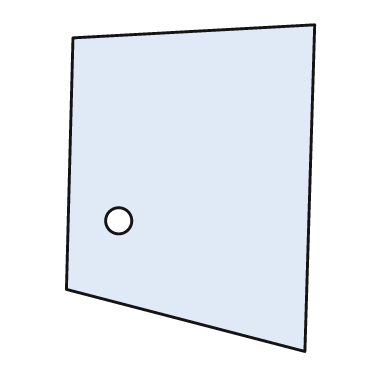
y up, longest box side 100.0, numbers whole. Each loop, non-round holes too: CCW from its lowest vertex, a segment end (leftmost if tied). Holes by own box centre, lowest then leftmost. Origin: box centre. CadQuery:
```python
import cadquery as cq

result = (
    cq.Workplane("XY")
    .moveTo(35.0, -50.0)
    .lineTo(38.0, 50.0)
    .lineTo(-36.0, 46.0)
    .lineTo(-38.0, -31.0)
    .close()
    .moveTo(-22.0, -10.0)
    .circle(4.0)
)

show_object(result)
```